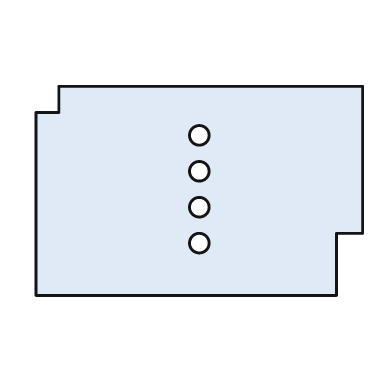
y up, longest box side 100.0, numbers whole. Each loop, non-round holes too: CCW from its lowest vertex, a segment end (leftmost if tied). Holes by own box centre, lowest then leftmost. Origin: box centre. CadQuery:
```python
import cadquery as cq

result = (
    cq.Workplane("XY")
    .moveTo(-50.0, -32.0)
    .lineTo(42.0, -32.0)
    .lineTo(42.0, -13.0)
    .lineTo(50.0, -13.0)
    .lineTo(50.0, 32.0)
    .lineTo(-43.0, 32.0)
    .lineTo(-43.0, 24.0)
    .lineTo(-50.0, 24.0)
    .close()
    .moveTo(0.0, -16.0)
    .circle(3.0)
    .moveTo(0.0, -5.0)
    .circle(3.0)
    .moveTo(0.0, 6.0)
    .circle(3.0)
    .moveTo(0.0, 17.0)
    .circle(3.0)
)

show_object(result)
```